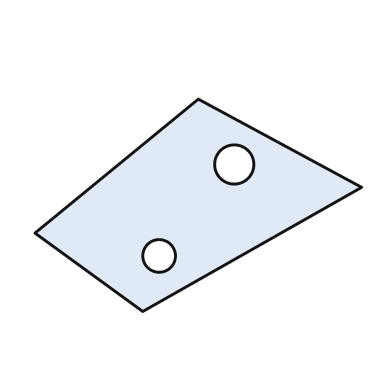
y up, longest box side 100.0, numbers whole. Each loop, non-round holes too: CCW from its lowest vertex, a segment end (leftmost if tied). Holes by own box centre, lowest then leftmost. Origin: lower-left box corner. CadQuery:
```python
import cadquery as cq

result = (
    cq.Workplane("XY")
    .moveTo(33.0, 0.0)
    .lineTo(100.0, 38.0)
    .lineTo(50.0, 65.0)
    .lineTo(0.0, 24.0)
    .close()
    .moveTo(38.0, 17.0)
    .circle(5.0)
    .moveTo(61.0, 45.0)
    .circle(6.0)
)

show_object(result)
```